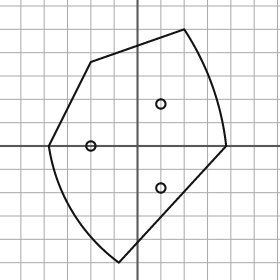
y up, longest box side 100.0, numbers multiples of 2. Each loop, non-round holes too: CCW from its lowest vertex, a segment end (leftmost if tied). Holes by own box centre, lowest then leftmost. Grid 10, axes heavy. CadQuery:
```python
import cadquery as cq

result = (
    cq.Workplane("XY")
    .moveTo(-8.0, -50.0)
    .lineTo(38.0, 0.0)
    .threePointArc((32.0, 26.0), (20.0, 50.0))
    .lineTo(-20.0, 36.0)
    .lineTo(-38.0, 0.0)
    .threePointArc((-28.0, -28.0), (-8.0, -50.0))
    .close()
    .moveTo(10.0, -18.0)
    .circle(2.0)
    .moveTo(-20.0, 0.0)
    .circle(2.0)
    .moveTo(10.0, 18.0)
    .circle(2.0)
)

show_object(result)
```